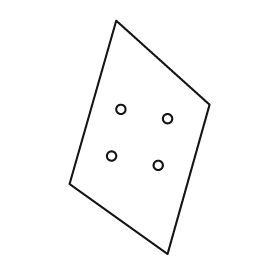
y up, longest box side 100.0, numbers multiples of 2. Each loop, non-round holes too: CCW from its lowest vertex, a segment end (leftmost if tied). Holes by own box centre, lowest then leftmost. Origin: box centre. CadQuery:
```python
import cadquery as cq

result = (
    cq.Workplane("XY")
    .moveTo(12.0, -50.0)
    .lineTo(30.0, 14.0)
    .lineTo(-10.0, 50.0)
    .lineTo(-30.0, -20.0)
    .close()
    .moveTo(8.0, -12.0)
    .circle(2.0)
    .moveTo(-12.0, -8.0)
    .circle(2.0)
    .moveTo(12.0, 8.0)
    .circle(2.0)
    .moveTo(-8.0, 12.0)
    .circle(2.0)
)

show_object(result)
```